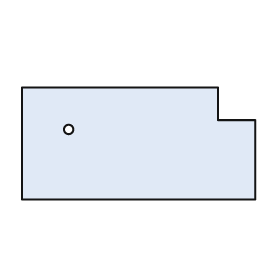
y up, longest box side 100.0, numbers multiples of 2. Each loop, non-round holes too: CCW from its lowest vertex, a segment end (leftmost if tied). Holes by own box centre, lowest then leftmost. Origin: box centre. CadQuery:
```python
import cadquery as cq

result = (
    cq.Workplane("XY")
    .moveTo(-50.0, -24.0)
    .lineTo(50.0, -24.0)
    .lineTo(50.0, 10.0)
    .lineTo(34.0, 10.0)
    .lineTo(34.0, 24.0)
    .lineTo(-50.0, 24.0)
    .close()
    .moveTo(-30.0, 6.0)
    .circle(2.0)
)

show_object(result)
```